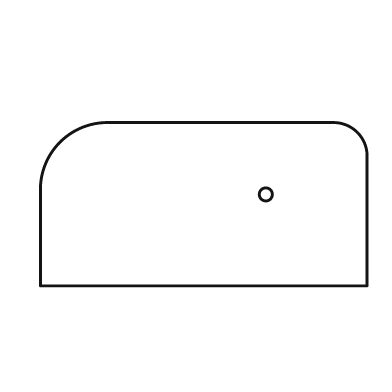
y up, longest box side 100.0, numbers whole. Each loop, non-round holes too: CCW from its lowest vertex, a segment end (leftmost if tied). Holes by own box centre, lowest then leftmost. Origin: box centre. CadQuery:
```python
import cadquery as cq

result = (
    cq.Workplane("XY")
    .moveTo(-50.0, -25.0)
    .lineTo(50.0, -25.0)
    .lineTo(50.0, 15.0)
    .threePointArc((47.0, 22.0), (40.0, 25.0))
    .lineTo(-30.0, 25.0)
    .threePointArc((-44.0, 19.0), (-50.0, 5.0))
    .close()
    .moveTo(19.0, 3.0)
    .circle(2.0)
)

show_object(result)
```